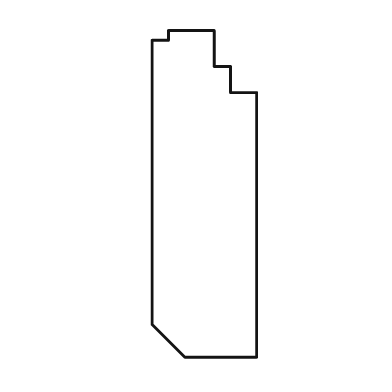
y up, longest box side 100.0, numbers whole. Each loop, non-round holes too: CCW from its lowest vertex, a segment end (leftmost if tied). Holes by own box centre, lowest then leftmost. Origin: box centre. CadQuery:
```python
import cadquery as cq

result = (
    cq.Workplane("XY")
    .moveTo(-6.0, -50.0)
    .lineTo(16.0, -50.0)
    .lineTo(16.0, 31.0)
    .lineTo(8.0, 31.0)
    .lineTo(8.0, 39.0)
    .lineTo(3.0, 39.0)
    .lineTo(3.0, 50.0)
    .lineTo(-11.0, 50.0)
    .lineTo(-11.0, 47.0)
    .lineTo(-16.0, 47.0)
    .lineTo(-16.0, -40.0)
    .close()
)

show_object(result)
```